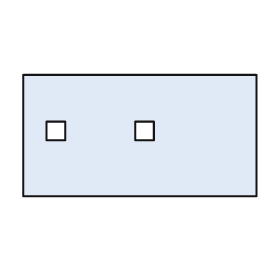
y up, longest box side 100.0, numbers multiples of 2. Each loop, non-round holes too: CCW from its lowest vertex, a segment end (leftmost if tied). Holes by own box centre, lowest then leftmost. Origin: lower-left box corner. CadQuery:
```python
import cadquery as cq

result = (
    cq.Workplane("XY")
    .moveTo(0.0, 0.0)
    .lineTo(100.0, 0.0)
    .lineTo(100.0, 52.0)
    .lineTo(0.0, 52.0)
    .close()
    .moveTo(10.0, 24.0)
    .lineTo(18.0, 24.0)
    .lineTo(18.0, 32.0)
    .lineTo(10.0, 32.0)
    .close()
    .moveTo(48.0, 24.0)
    .lineTo(56.0, 24.0)
    .lineTo(56.0, 32.0)
    .lineTo(48.0, 32.0)
    .close()
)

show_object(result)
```